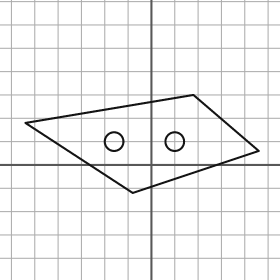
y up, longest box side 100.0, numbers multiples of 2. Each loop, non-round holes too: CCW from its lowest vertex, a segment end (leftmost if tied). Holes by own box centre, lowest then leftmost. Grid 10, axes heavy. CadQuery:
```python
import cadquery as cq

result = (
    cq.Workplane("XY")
    .moveTo(-8.0, -12.0)
    .lineTo(46.0, 6.0)
    .lineTo(18.0, 30.0)
    .lineTo(-54.0, 18.0)
    .close()
    .moveTo(-16.0, 10.0)
    .circle(4.0)
    .moveTo(10.0, 10.0)
    .circle(4.0)
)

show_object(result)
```